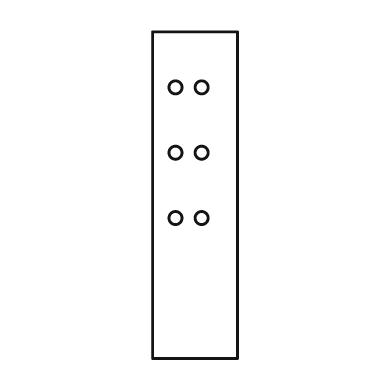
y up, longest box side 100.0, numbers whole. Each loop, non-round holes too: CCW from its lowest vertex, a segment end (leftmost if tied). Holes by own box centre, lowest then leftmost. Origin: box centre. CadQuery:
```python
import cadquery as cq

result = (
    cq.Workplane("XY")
    .moveTo(-13.0, -50.0)
    .lineTo(13.0, -50.0)
    .lineTo(13.0, 50.0)
    .lineTo(-13.0, 50.0)
    .close()
    .moveTo(-6.0, -7.0)
    .circle(2.0)
    .moveTo(2.0, -7.0)
    .circle(2.0)
    .moveTo(-6.0, 13.0)
    .circle(2.0)
    .moveTo(2.0, 13.0)
    .circle(2.0)
    .moveTo(-6.0, 33.0)
    .circle(2.0)
    .moveTo(2.0, 33.0)
    .circle(2.0)
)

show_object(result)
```